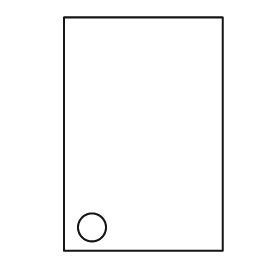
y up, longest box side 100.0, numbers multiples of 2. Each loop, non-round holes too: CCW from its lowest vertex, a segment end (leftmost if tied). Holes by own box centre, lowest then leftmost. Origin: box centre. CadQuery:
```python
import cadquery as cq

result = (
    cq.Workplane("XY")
    .moveTo(-34.0, -50.0)
    .lineTo(34.0, -50.0)
    .lineTo(34.0, 50.0)
    .lineTo(-34.0, 50.0)
    .close()
    .moveTo(-22.0, -40.0)
    .circle(6.0)
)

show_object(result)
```